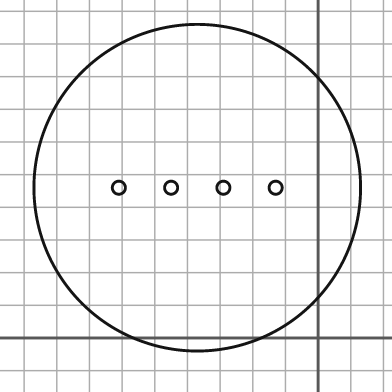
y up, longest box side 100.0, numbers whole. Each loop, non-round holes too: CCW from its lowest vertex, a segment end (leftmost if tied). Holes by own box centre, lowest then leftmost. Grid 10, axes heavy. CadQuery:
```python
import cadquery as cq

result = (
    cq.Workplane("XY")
    .moveTo(-37.0, 46.0)
    .circle(50.0)
    .moveTo(-61.0, 46.0)
    .circle(2.0)
    .moveTo(-45.0, 46.0)
    .circle(2.0)
    .moveTo(-29.0, 46.0)
    .circle(2.0)
    .moveTo(-13.0, 46.0)
    .circle(2.0)
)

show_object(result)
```